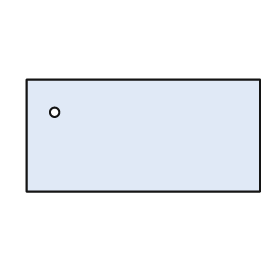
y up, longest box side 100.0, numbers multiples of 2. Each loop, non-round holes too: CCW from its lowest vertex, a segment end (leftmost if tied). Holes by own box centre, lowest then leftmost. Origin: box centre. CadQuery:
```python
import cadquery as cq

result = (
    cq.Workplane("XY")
    .moveTo(-50.0, -24.0)
    .lineTo(50.0, -24.0)
    .lineTo(50.0, 24.0)
    .lineTo(-50.0, 24.0)
    .close()
    .moveTo(-38.0, 10.0)
    .circle(2.0)
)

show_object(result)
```